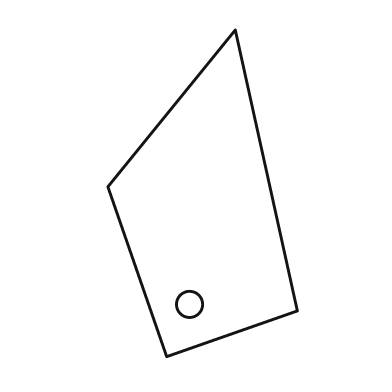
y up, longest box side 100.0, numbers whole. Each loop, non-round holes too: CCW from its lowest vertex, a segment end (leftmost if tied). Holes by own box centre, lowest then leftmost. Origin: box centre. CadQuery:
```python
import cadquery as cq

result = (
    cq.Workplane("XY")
    .moveTo(-11.0, -50.0)
    .lineTo(29.0, -36.0)
    .lineTo(10.0, 50.0)
    .lineTo(-29.0, 2.0)
    .close()
    .moveTo(-4.0, -34.0)
    .circle(4.0)
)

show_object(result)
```